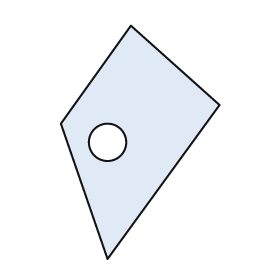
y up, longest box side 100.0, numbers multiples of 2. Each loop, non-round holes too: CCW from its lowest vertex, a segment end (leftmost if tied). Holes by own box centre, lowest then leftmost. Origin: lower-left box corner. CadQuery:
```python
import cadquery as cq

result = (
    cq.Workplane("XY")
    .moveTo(20.0, 0.0)
    .lineTo(68.0, 66.0)
    .lineTo(30.0, 100.0)
    .lineTo(0.0, 58.0)
    .close()
    .moveTo(20.0, 50.0)
    .circle(8.0)
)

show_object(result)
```